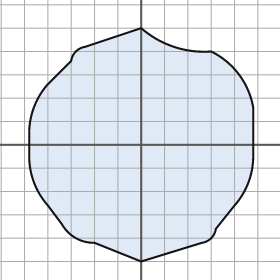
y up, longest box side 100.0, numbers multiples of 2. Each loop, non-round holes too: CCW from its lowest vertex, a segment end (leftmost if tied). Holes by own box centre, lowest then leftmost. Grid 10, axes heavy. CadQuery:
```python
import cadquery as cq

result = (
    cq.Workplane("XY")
    .moveTo(0.0, -50.0)
    .lineTo(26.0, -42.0)
    .threePointArc((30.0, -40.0), (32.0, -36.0))
    .lineTo(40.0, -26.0)
    .threePointArc((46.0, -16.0), (48.0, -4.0))
    .lineTo(48.0, 16.0)
    .threePointArc((42.0, 30.0), (30.0, 40.0))
    .threePointArc((14.0, 42.0), (0.0, 50.0))
    .lineTo(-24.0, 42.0)
    .threePointArc((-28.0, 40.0), (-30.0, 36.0))
    .lineTo(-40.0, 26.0)
    .threePointArc((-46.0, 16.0), (-48.0, 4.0))
    .lineTo(-48.0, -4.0)
    .threePointArc((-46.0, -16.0), (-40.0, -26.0))
    .lineTo(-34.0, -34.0)
    .threePointArc((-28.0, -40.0), (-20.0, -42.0))
    .close()
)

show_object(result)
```